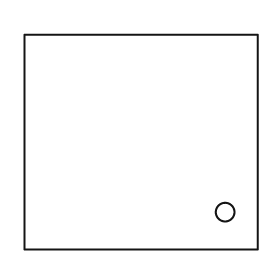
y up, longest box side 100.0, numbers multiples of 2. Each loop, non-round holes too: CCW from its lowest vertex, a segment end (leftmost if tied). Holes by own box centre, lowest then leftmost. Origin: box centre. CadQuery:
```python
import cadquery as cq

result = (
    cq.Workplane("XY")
    .moveTo(-50.0, -46.0)
    .lineTo(50.0, -46.0)
    .lineTo(50.0, 46.0)
    .lineTo(-50.0, 46.0)
    .close()
    .moveTo(36.0, -30.0)
    .circle(4.0)
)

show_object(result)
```